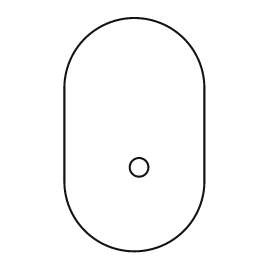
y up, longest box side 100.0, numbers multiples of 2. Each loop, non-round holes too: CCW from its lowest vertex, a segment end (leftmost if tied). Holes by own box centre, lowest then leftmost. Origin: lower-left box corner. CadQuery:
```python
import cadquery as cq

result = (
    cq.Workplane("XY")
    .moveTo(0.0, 30.0)
    .threePointArc((30.0, 0.0), (60.0, 30.0))
    .lineTo(60.0, 70.0)
    .threePointArc((30.0, 100.0), (0.0, 70.0))
    .close()
    .moveTo(32.0, 36.0)
    .circle(4.0)
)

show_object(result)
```